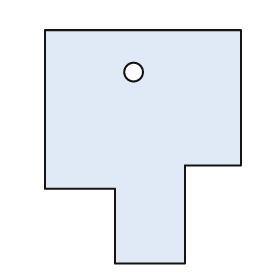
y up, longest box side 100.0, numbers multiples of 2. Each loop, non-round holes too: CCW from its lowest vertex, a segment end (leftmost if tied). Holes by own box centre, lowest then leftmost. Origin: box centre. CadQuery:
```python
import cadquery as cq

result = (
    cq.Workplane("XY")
    .moveTo(-12.0, -50.0)
    .lineTo(18.0, -50.0)
    .lineTo(18.0, -8.0)
    .lineTo(42.0, -8.0)
    .lineTo(42.0, 50.0)
    .lineTo(-42.0, 50.0)
    .lineTo(-42.0, -18.0)
    .lineTo(-12.0, -18.0)
    .close()
    .moveTo(-4.0, 32.0)
    .circle(4.0)
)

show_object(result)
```